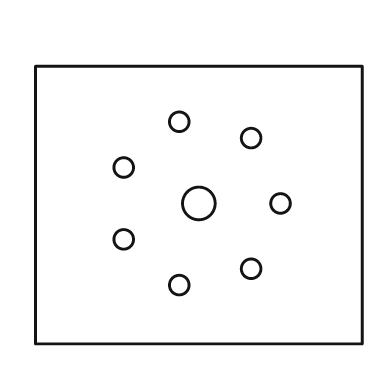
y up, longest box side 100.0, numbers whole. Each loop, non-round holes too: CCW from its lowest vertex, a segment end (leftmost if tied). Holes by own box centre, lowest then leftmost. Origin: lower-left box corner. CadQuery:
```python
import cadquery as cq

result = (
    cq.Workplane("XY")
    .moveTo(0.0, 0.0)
    .lineTo(100.0, 0.0)
    .lineTo(100.0, 85.0)
    .lineTo(0.0, 85.0)
    .close()
    .moveTo(44.0, 18.0)
    .circle(3.0)
    .moveTo(66.0, 23.0)
    .circle(3.0)
    .moveTo(27.0, 32.0)
    .circle(3.0)
    .moveTo(50.0, 43.0)
    .circle(5.0)
    .moveTo(75.0, 43.0)
    .circle(3.0)
    .moveTo(27.0, 54.0)
    .circle(3.0)
    .moveTo(66.0, 63.0)
    .circle(3.0)
    .moveTo(44.0, 68.0)
    .circle(3.0)
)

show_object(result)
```